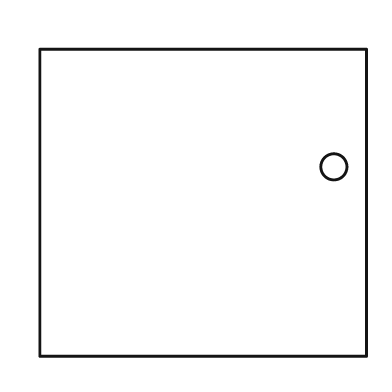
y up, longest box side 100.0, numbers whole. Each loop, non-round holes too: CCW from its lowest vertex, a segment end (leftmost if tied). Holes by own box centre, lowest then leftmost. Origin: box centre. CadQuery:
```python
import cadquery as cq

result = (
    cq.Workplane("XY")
    .moveTo(-50.0, -47.0)
    .lineTo(50.0, -47.0)
    .lineTo(50.0, 47.0)
    .lineTo(-50.0, 47.0)
    .close()
    .moveTo(40.0, 11.0)
    .circle(4.0)
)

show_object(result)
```